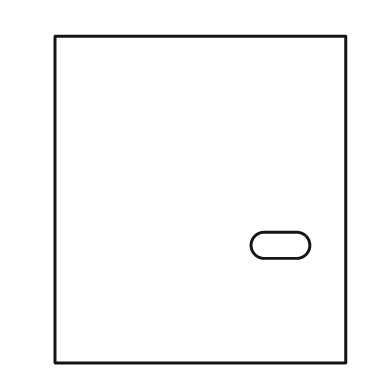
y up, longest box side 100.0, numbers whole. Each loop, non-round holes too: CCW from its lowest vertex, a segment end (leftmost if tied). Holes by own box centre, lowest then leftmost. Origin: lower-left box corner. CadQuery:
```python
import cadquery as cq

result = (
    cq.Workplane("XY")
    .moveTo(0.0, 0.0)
    .lineTo(89.0, 0.0)
    .lineTo(89.0, 100.0)
    .lineTo(0.0, 100.0)
    .close()
    .moveTo(64.0, 32.0)
    .lineTo(74.0, 32.0)
    .threePointArc((78.0, 36.0), (74.0, 40.0))
    .lineTo(64.0, 40.0)
    .threePointArc((60.0, 36.0), (64.0, 32.0))
    .close()
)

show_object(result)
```